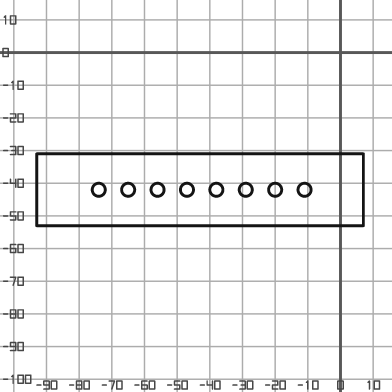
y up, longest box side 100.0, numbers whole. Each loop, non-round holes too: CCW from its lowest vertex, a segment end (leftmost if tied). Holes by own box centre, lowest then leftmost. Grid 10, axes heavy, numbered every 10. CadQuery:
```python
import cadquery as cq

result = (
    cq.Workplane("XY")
    .moveTo(-93.0, -53.0)
    .lineTo(7.0, -53.0)
    .lineTo(7.0, -31.0)
    .lineTo(-93.0, -31.0)
    .close()
    .moveTo(-74.0, -42.0)
    .circle(2.0)
    .moveTo(-65.0, -42.0)
    .circle(2.0)
    .moveTo(-56.0, -42.0)
    .circle(2.0)
    .moveTo(-47.0, -42.0)
    .circle(2.0)
    .moveTo(-38.0, -42.0)
    .circle(2.0)
    .moveTo(-29.0, -42.0)
    .circle(2.0)
    .moveTo(-20.0, -42.0)
    .circle(2.0)
    .moveTo(-11.0, -42.0)
    .circle(2.0)
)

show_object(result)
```